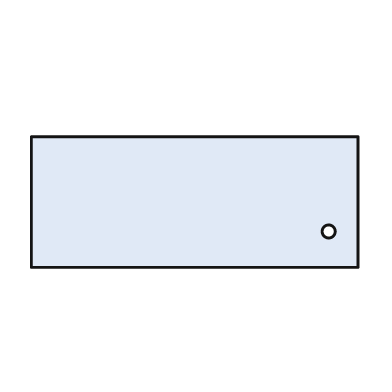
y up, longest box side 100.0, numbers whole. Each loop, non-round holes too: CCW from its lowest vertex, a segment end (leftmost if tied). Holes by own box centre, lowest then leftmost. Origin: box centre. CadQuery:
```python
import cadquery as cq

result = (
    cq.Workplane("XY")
    .moveTo(-50.0, -20.0)
    .lineTo(50.0, -20.0)
    .lineTo(50.0, 20.0)
    .lineTo(-50.0, 20.0)
    .close()
    .moveTo(41.0, -9.0)
    .circle(2.0)
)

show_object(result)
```